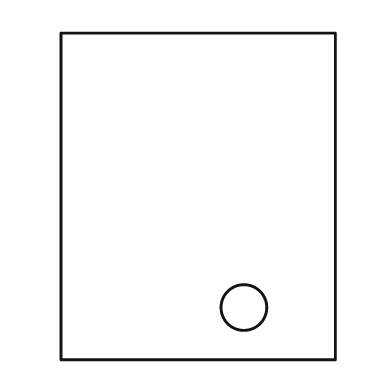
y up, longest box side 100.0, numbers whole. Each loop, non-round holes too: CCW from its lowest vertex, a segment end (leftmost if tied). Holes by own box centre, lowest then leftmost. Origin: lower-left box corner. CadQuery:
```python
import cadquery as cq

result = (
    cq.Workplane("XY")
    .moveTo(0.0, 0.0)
    .lineTo(84.0, 0.0)
    .lineTo(84.0, 100.0)
    .lineTo(0.0, 100.0)
    .close()
    .moveTo(56.0, 16.0)
    .circle(7.0)
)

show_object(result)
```